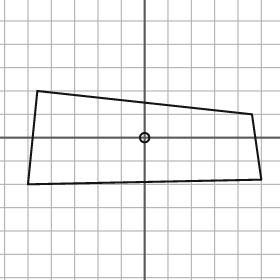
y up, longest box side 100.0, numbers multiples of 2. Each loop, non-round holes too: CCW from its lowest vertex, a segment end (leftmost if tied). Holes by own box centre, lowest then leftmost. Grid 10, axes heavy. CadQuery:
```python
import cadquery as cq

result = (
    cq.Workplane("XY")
    .moveTo(-50.0, -20.0)
    .lineTo(50.0, -18.0)
    .lineTo(46.0, 10.0)
    .lineTo(-46.0, 20.0)
    .close()
    .moveTo(0.0, 0.0)
    .circle(2.0)
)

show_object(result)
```